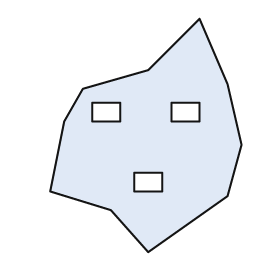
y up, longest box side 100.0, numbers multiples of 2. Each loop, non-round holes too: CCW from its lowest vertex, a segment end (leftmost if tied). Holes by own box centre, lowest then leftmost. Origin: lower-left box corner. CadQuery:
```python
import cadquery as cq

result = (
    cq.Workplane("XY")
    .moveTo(42.0, 0.0)
    .lineTo(76.0, 24.0)
    .lineTo(82.0, 46.0)
    .lineTo(76.0, 72.0)
    .lineTo(64.0, 100.0)
    .lineTo(42.0, 78.0)
    .lineTo(14.0, 70.0)
    .lineTo(6.0, 56.0)
    .lineTo(0.0, 26.0)
    .lineTo(26.0, 18.0)
    .close()
    .moveTo(36.0, 26.0)
    .lineTo(48.0, 26.0)
    .lineTo(48.0, 34.0)
    .lineTo(36.0, 34.0)
    .close()
    .moveTo(18.0, 56.0)
    .lineTo(30.0, 56.0)
    .lineTo(30.0, 64.0)
    .lineTo(18.0, 64.0)
    .close()
    .moveTo(52.0, 56.0)
    .lineTo(64.0, 56.0)
    .lineTo(64.0, 64.0)
    .lineTo(52.0, 64.0)
    .close()
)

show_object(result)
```